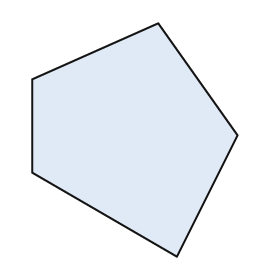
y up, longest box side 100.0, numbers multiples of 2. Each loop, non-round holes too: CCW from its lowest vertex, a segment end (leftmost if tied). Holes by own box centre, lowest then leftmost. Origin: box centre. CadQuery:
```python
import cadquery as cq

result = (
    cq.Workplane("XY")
    .moveTo(18.0, -50.0)
    .lineTo(44.0, 2.0)
    .lineTo(10.0, 50.0)
    .lineTo(-44.0, 26.0)
    .lineTo(-44.0, -14.0)
    .close()
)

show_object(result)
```